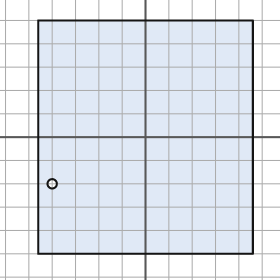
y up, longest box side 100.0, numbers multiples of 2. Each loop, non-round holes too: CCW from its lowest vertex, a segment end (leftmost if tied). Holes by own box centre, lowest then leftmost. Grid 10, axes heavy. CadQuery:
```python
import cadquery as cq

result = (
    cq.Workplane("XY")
    .moveTo(-46.0, -50.0)
    .lineTo(46.0, -50.0)
    .lineTo(46.0, 50.0)
    .lineTo(-46.0, 50.0)
    .close()
    .moveTo(-40.0, -20.0)
    .circle(2.0)
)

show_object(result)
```